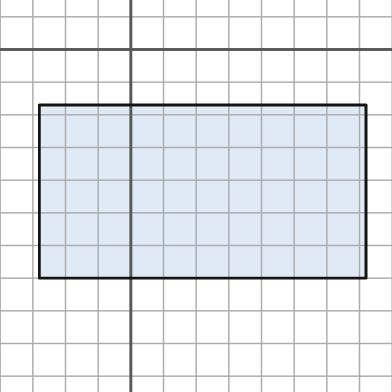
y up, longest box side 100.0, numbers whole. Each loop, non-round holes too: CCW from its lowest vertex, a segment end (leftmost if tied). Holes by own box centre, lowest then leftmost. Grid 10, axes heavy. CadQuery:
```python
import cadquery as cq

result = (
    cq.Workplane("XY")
    .moveTo(-28.0, -70.0)
    .lineTo(72.0, -70.0)
    .lineTo(72.0, -17.0)
    .lineTo(-28.0, -17.0)
    .close()
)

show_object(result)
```